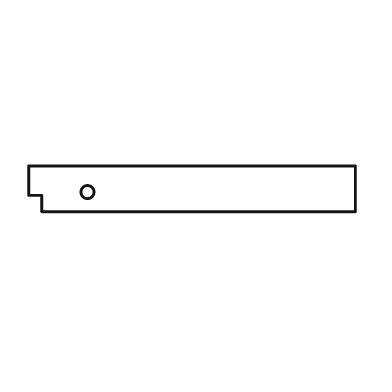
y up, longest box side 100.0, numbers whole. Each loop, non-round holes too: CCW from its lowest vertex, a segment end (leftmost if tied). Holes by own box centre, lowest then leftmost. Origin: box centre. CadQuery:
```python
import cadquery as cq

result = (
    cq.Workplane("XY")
    .moveTo(-46.0, -7.0)
    .lineTo(50.0, -7.0)
    .lineTo(50.0, 7.0)
    .lineTo(-50.0, 7.0)
    .lineTo(-50.0, -2.0)
    .lineTo(-46.0, -2.0)
    .close()
    .moveTo(-32.0, -1.0)
    .circle(2.0)
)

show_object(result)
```